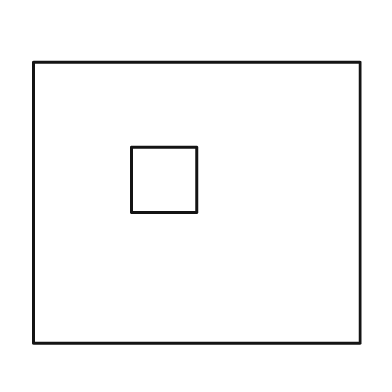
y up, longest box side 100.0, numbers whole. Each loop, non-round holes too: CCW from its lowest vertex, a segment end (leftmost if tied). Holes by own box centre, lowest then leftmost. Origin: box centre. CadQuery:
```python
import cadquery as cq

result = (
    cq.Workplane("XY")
    .moveTo(-50.0, -43.0)
    .lineTo(50.0, -43.0)
    .lineTo(50.0, 43.0)
    .lineTo(-50.0, 43.0)
    .close()
    .moveTo(-20.0, -3.0)
    .lineTo(0.0, -3.0)
    .lineTo(0.0, 17.0)
    .lineTo(-20.0, 17.0)
    .close()
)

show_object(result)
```